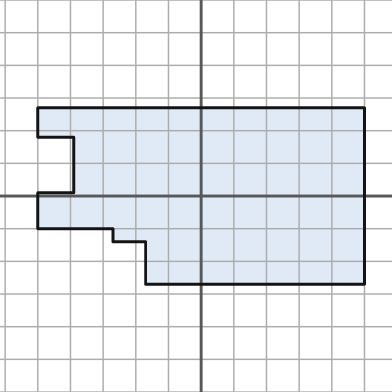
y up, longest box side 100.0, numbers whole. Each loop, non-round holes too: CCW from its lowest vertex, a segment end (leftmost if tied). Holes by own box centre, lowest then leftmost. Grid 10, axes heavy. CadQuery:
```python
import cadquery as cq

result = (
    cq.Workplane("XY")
    .moveTo(-17.0, -27.0)
    .lineTo(50.0, -27.0)
    .lineTo(50.0, 27.0)
    .lineTo(-50.0, 27.0)
    .lineTo(-50.0, 18.0)
    .lineTo(-39.0, 18.0)
    .lineTo(-39.0, 1.0)
    .lineTo(-50.0, 1.0)
    .lineTo(-50.0, -10.0)
    .lineTo(-27.0, -10.0)
    .lineTo(-27.0, -14.0)
    .lineTo(-17.0, -14.0)
    .close()
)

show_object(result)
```